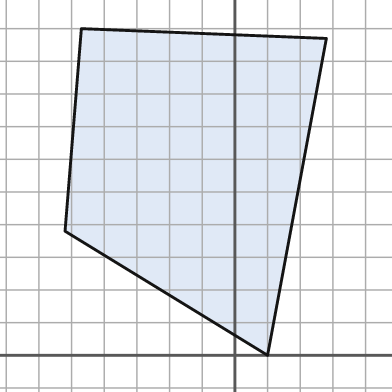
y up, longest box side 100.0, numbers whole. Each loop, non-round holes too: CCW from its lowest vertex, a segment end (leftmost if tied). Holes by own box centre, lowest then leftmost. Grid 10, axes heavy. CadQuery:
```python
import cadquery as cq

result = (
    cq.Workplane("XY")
    .moveTo(10.0, 0.0)
    .lineTo(28.0, 97.0)
    .lineTo(-47.0, 100.0)
    .lineTo(-52.0, 38.0)
    .close()
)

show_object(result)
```